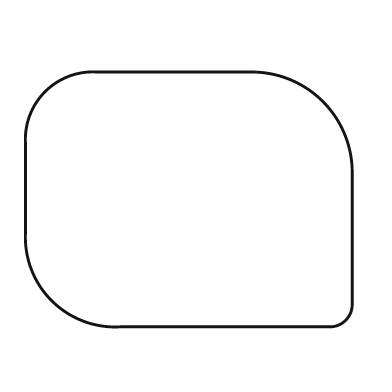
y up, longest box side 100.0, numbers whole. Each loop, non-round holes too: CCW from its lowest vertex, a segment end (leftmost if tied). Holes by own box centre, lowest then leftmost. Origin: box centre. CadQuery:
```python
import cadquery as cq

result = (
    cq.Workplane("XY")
    .moveTo(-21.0, -39.0)
    .lineTo(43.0, -39.0)
    .threePointArc((48.0, -37.0), (50.0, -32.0))
    .lineTo(50.0, 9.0)
    .threePointArc((41.0, 30.0), (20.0, 39.0))
    .lineTo(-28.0, 39.0)
    .threePointArc((-44.0, 33.0), (-50.0, 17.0))
    .lineTo(-50.0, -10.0)
    .threePointArc((-42.0, -31.0), (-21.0, -39.0))
    .close()
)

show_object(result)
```